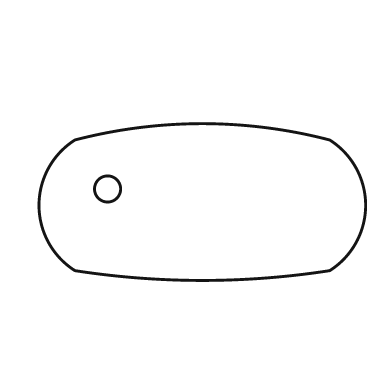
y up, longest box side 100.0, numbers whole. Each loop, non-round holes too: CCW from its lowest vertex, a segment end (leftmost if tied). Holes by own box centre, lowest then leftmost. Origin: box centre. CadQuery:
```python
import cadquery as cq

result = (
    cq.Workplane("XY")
    .moveTo(-39.0, -21.0)
    .threePointArc((0.0, -24.0), (39.0, -21.0))
    .threePointArc((50.0, -1.0), (39.0, 19.0))
    .threePointArc((0.0, 24.0), (-39.0, 19.0))
    .threePointArc((-50.0, -1.0), (-39.0, -21.0))
    .close()
    .moveTo(-29.0, 4.0)
    .circle(4.0)
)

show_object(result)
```